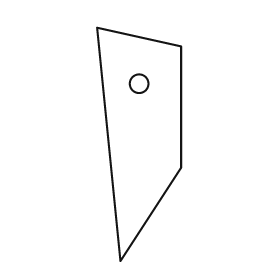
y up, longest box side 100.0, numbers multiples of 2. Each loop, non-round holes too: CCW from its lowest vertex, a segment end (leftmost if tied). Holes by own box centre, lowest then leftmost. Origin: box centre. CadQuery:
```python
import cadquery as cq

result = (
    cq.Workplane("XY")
    .moveTo(-8.0, -50.0)
    .lineTo(18.0, -10.0)
    .lineTo(18.0, 42.0)
    .lineTo(-18.0, 50.0)
    .close()
    .moveTo(0.0, 26.0)
    .circle(4.0)
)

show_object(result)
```